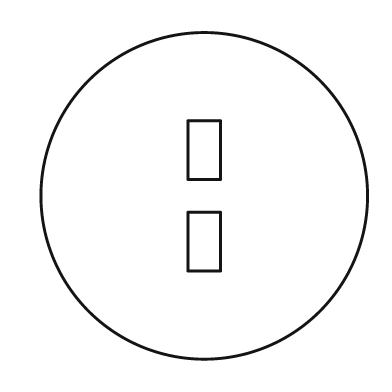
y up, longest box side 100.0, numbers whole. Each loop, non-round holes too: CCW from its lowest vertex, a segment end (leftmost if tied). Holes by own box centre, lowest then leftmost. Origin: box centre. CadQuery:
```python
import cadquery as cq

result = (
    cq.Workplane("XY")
    .moveTo(0.0, 0.0)
    .circle(50.0)
    .moveTo(-5.0, -23.0)
    .lineTo(5.0, -23.0)
    .lineTo(5.0, -5.0)
    .lineTo(-5.0, -5.0)
    .close()
    .moveTo(-5.0, 5.0)
    .lineTo(5.0, 5.0)
    .lineTo(5.0, 23.0)
    .lineTo(-5.0, 23.0)
    .close()
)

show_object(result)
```